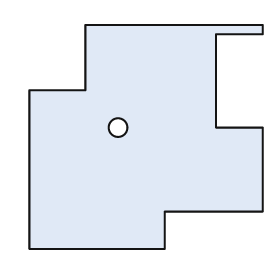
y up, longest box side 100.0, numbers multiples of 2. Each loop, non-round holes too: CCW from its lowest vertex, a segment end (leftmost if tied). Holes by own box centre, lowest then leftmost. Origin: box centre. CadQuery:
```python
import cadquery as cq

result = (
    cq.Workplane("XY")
    .moveTo(-50.0, -48.0)
    .lineTo(8.0, -48.0)
    .lineTo(8.0, -32.0)
    .lineTo(50.0, -32.0)
    .lineTo(50.0, 4.0)
    .lineTo(30.0, 4.0)
    .lineTo(30.0, 44.0)
    .lineTo(50.0, 44.0)
    .lineTo(50.0, 48.0)
    .lineTo(-26.0, 48.0)
    .lineTo(-26.0, 20.0)
    .lineTo(-50.0, 20.0)
    .close()
    .moveTo(-12.0, 4.0)
    .circle(4.0)
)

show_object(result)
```